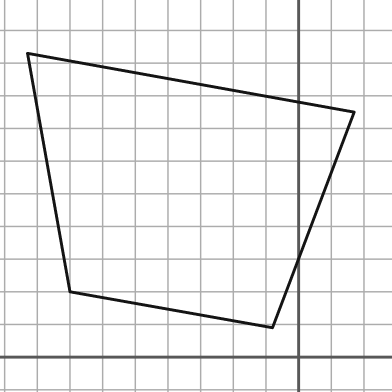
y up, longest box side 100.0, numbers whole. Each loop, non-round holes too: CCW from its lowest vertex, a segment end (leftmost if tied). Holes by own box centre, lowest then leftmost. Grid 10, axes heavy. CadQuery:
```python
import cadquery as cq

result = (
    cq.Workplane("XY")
    .moveTo(-8.0, 9.0)
    .lineTo(17.0, 75.0)
    .lineTo(-83.0, 93.0)
    .lineTo(-70.0, 20.0)
    .close()
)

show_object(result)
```